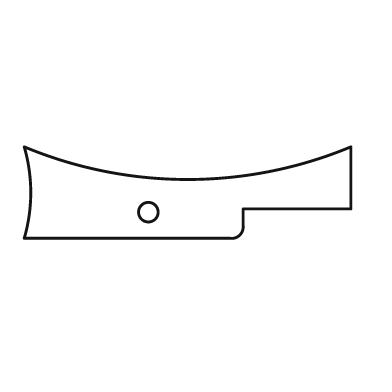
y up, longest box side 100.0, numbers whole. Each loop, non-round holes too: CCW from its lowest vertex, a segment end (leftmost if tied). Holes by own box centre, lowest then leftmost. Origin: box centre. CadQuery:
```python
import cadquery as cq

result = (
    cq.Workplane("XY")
    .moveTo(-50.0, -14.0)
    .lineTo(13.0, -14.0)
    .threePointArc((16.0, -13.0), (17.0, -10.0))
    .lineTo(17.0, -5.0)
    .lineTo(50.0, -5.0)
    .lineTo(50.0, 14.0)
    .threePointArc((0.0, 4.0), (-50.0, 14.0))
    .threePointArc((-48.0, 0.0), (-50.0, -14.0))
    .close()
    .moveTo(-12.0, -6.0)
    .circle(3.0)
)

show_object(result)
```